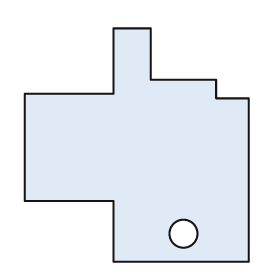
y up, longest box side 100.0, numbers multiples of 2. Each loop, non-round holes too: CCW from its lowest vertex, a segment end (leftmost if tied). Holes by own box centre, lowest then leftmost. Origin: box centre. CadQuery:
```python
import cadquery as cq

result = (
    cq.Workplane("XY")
    .moveTo(-10.0, -50.0)
    .lineTo(48.0, -50.0)
    .lineTo(48.0, 20.0)
    .lineTo(34.0, 20.0)
    .lineTo(34.0, 28.0)
    .lineTo(6.0, 28.0)
    .lineTo(6.0, 50.0)
    .lineTo(-10.0, 50.0)
    .lineTo(-10.0, 22.0)
    .lineTo(-48.0, 22.0)
    .lineTo(-48.0, -24.0)
    .lineTo(-10.0, -24.0)
    .close()
    .moveTo(20.0, -38.0)
    .circle(6.0)
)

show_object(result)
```